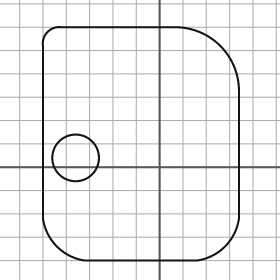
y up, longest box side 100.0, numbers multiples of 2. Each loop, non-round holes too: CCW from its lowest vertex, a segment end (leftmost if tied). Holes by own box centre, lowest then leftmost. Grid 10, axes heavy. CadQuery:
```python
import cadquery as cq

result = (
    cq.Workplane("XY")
    .moveTo(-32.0, -40.0)
    .lineTo(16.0, -40.0)
    .threePointArc((28.0, -34.0), (34.0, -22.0))
    .lineTo(34.0, 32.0)
    .threePointArc((26.0, 52.0), (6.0, 60.0))
    .lineTo(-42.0, 60.0)
    .threePointArc((-48.0, 58.0), (-50.0, 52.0))
    .lineTo(-50.0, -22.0)
    .threePointArc((-44.0, -34.0), (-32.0, -40.0))
    .close()
    .moveTo(-36.0, 4.0)
    .circle(10.0)
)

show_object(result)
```